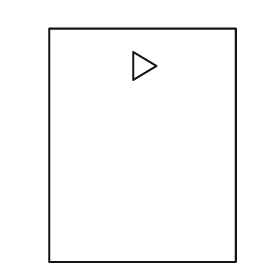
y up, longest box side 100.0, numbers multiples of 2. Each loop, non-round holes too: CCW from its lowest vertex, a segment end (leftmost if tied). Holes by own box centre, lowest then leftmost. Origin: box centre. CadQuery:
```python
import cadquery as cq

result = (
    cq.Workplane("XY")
    .moveTo(-40.0, -50.0)
    .lineTo(40.0, -50.0)
    .lineTo(40.0, 50.0)
    .lineTo(-40.0, 50.0)
    .close()
    .moveTo(-4.0, 28.0)
    .lineTo(6.0, 34.0)
    .lineTo(-4.0, 40.0)
    .close()
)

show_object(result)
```